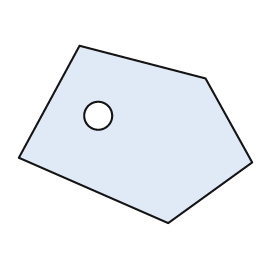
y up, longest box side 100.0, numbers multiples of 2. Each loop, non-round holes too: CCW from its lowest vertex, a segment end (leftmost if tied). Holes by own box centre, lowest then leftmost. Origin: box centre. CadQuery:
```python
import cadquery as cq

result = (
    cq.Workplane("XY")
    .moveTo(14.0, -38.0)
    .lineTo(50.0, -12.0)
    .lineTo(30.0, 24.0)
    .lineTo(-24.0, 38.0)
    .lineTo(-50.0, -10.0)
    .close()
    .moveTo(-16.0, 8.0)
    .circle(6.0)
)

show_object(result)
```